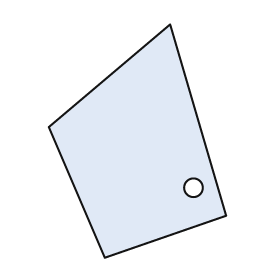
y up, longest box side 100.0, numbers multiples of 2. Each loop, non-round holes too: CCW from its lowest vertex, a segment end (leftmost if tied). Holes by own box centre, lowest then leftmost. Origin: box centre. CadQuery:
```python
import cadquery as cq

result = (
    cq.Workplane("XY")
    .moveTo(-14.0, -50.0)
    .lineTo(38.0, -32.0)
    .lineTo(14.0, 50.0)
    .lineTo(-38.0, 6.0)
    .close()
    .moveTo(24.0, -20.0)
    .circle(4.0)
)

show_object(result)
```